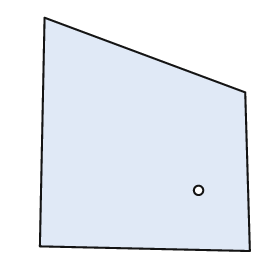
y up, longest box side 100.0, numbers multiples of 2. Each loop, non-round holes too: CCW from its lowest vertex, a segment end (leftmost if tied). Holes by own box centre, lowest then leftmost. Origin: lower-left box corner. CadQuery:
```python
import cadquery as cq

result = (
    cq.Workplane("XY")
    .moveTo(90.0, 0.0)
    .lineTo(88.0, 68.0)
    .lineTo(2.0, 100.0)
    .lineTo(0.0, 2.0)
    .close()
    .moveTo(68.0, 26.0)
    .circle(2.0)
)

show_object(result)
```